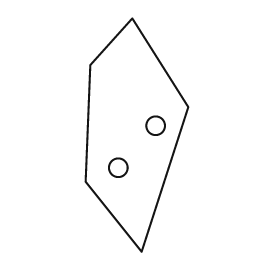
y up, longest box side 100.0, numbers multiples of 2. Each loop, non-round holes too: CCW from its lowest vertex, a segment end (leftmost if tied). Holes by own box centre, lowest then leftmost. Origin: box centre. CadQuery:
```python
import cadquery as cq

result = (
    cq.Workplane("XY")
    .moveTo(2.0, -50.0)
    .lineTo(22.0, 12.0)
    .lineTo(-2.0, 50.0)
    .lineTo(-20.0, 30.0)
    .lineTo(-22.0, -20.0)
    .close()
    .moveTo(-8.0, -14.0)
    .circle(4.0)
    .moveTo(8.0, 4.0)
    .circle(4.0)
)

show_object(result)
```